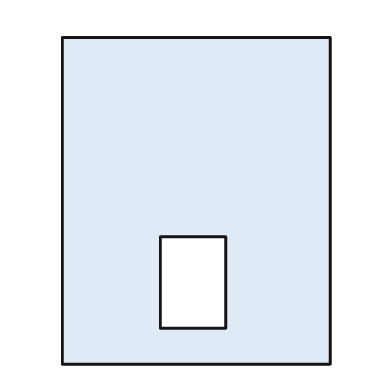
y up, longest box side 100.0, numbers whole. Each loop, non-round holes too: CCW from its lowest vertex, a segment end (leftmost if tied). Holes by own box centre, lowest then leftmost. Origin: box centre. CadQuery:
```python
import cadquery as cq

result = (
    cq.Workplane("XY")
    .moveTo(-41.0, -50.0)
    .lineTo(41.0, -50.0)
    .lineTo(41.0, 50.0)
    .lineTo(-41.0, 50.0)
    .close()
    .moveTo(-11.0, -39.0)
    .lineTo(9.0, -39.0)
    .lineTo(9.0, -11.0)
    .lineTo(-11.0, -11.0)
    .close()
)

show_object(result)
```